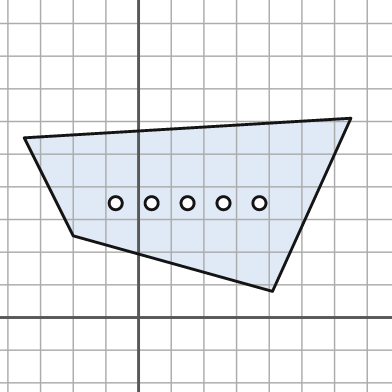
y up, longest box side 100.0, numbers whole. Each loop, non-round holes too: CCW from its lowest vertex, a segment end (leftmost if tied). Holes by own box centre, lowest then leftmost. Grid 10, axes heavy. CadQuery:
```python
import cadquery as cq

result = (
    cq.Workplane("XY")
    .moveTo(41.0, 8.0)
    .lineTo(65.0, 61.0)
    .lineTo(-35.0, 55.0)
    .lineTo(-20.0, 25.0)
    .close()
    .moveTo(-7.0, 35.0)
    .circle(2.0)
    .moveTo(4.0, 35.0)
    .circle(2.0)
    .moveTo(15.0, 35.0)
    .circle(2.0)
    .moveTo(26.0, 35.0)
    .circle(2.0)
    .moveTo(37.0, 35.0)
    .circle(2.0)
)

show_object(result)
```